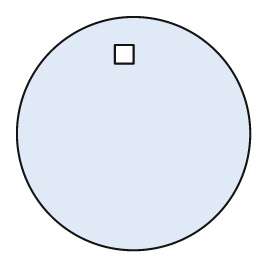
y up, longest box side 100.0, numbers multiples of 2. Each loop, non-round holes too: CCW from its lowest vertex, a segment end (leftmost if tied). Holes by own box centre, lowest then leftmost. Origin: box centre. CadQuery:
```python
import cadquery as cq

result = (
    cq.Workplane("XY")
    .moveTo(0.0, 0.0)
    .circle(50.0)
    .moveTo(-8.0, 30.0)
    .lineTo(0.0, 30.0)
    .lineTo(0.0, 38.0)
    .lineTo(-8.0, 38.0)
    .close()
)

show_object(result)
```